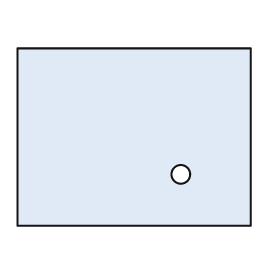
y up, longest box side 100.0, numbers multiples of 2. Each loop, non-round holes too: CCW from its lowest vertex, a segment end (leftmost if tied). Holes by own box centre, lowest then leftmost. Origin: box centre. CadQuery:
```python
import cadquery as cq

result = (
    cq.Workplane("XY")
    .moveTo(-50.0, -38.0)
    .lineTo(50.0, -38.0)
    .lineTo(50.0, 38.0)
    .lineTo(-50.0, 38.0)
    .close()
    .moveTo(20.0, -16.0)
    .circle(4.0)
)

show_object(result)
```